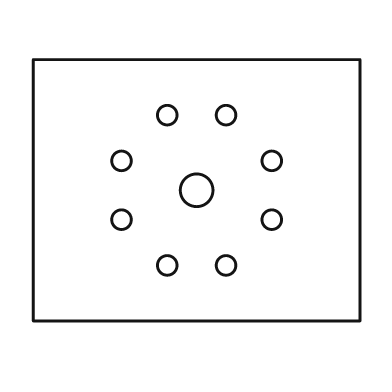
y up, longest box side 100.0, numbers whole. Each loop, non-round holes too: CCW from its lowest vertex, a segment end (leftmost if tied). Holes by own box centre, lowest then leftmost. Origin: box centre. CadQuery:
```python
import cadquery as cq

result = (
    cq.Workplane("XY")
    .moveTo(-50.0, -40.0)
    .lineTo(50.0, -40.0)
    .lineTo(50.0, 40.0)
    .lineTo(-50.0, 40.0)
    .close()
    .moveTo(-9.0, -23.0)
    .circle(3.0)
    .moveTo(9.0, -23.0)
    .circle(3.0)
    .moveTo(-23.0, -9.0)
    .circle(3.0)
    .moveTo(23.0, -9.0)
    .circle(3.0)
    .moveTo(0.0, 0.0)
    .circle(5.0)
    .moveTo(-23.0, 9.0)
    .circle(3.0)
    .moveTo(23.0, 9.0)
    .circle(3.0)
    .moveTo(-9.0, 23.0)
    .circle(3.0)
    .moveTo(9.0, 23.0)
    .circle(3.0)
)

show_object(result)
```